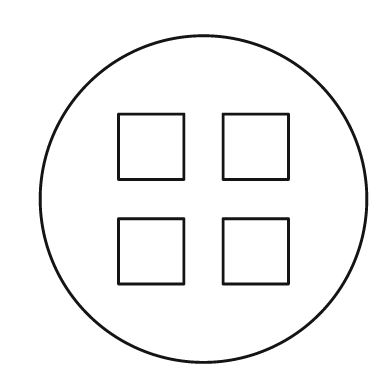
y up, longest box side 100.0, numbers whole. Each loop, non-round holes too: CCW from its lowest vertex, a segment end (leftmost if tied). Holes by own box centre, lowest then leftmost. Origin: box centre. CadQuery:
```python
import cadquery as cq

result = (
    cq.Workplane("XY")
    .moveTo(0.0, 0.0)
    .circle(50.0)
    .moveTo(-26.0, -26.0)
    .lineTo(-6.0, -26.0)
    .lineTo(-6.0, -6.0)
    .lineTo(-26.0, -6.0)
    .close()
    .moveTo(6.0, -26.0)
    .lineTo(26.0, -26.0)
    .lineTo(26.0, -6.0)
    .lineTo(6.0, -6.0)
    .close()
    .moveTo(-26.0, 6.0)
    .lineTo(-6.0, 6.0)
    .lineTo(-6.0, 26.0)
    .lineTo(-26.0, 26.0)
    .close()
    .moveTo(6.0, 6.0)
    .lineTo(26.0, 6.0)
    .lineTo(26.0, 26.0)
    .lineTo(6.0, 26.0)
    .close()
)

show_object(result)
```